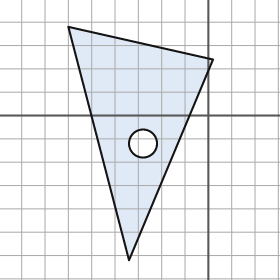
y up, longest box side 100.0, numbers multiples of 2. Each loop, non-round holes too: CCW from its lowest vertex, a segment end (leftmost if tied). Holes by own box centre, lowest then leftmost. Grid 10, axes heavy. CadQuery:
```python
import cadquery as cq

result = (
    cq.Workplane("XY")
    .moveTo(-34.0, -62.0)
    .lineTo(2.0, 24.0)
    .lineTo(-60.0, 38.0)
    .close()
    .moveTo(-28.0, -12.0)
    .circle(6.0)
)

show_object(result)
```